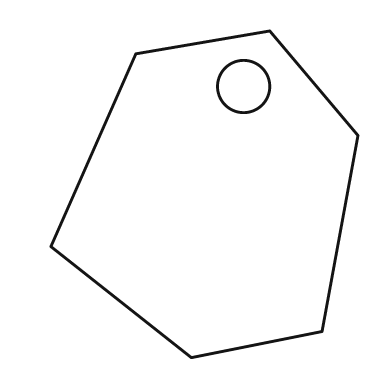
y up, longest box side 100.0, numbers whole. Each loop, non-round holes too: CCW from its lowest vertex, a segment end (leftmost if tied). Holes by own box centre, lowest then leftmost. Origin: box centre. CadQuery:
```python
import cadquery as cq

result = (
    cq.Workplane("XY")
    .moveTo(-4.0, -50.0)
    .lineTo(36.0, -42.0)
    .lineTo(47.0, 18.0)
    .lineTo(20.0, 50.0)
    .lineTo(-21.0, 43.0)
    .lineTo(-47.0, -16.0)
    .close()
    .moveTo(12.0, 33.0)
    .circle(8.0)
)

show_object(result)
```